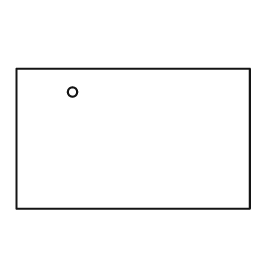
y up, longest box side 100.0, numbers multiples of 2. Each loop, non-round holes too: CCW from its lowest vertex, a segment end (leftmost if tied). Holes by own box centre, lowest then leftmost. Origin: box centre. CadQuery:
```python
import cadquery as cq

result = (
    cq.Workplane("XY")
    .moveTo(-50.0, -30.0)
    .lineTo(50.0, -30.0)
    .lineTo(50.0, 30.0)
    .lineTo(-50.0, 30.0)
    .close()
    .moveTo(-26.0, 20.0)
    .circle(2.0)
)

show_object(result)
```